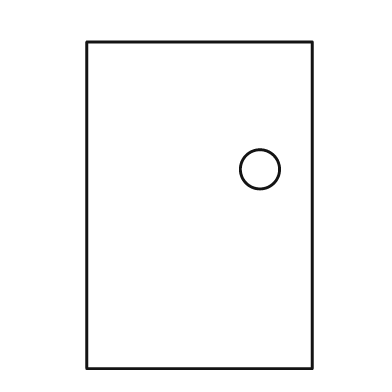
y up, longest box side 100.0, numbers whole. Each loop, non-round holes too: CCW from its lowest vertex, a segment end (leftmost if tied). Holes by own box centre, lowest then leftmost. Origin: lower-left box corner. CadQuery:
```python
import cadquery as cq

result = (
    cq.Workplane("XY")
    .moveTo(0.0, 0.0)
    .lineTo(69.0, 0.0)
    .lineTo(69.0, 100.0)
    .lineTo(0.0, 100.0)
    .close()
    .moveTo(53.0, 61.0)
    .circle(6.0)
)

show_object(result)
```